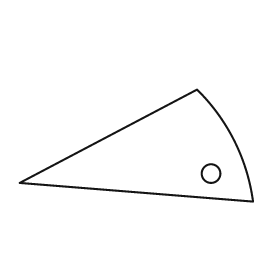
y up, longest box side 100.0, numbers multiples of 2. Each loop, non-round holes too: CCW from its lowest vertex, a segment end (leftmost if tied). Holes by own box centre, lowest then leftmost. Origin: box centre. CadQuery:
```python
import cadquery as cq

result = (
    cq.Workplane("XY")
    .moveTo(50.0, -24.0)
    .threePointArc((42.0, 2.0), (26.0, 24.0))
    .lineTo(-50.0, -16.0)
    .close()
    .moveTo(32.0, -12.0)
    .circle(4.0)
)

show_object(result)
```